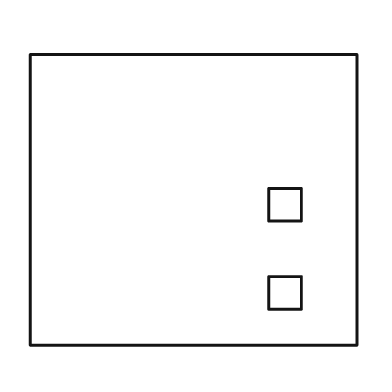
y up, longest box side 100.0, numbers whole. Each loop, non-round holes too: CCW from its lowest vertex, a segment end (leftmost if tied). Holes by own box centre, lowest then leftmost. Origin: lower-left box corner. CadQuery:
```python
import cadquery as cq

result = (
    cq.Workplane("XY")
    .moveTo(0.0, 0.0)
    .lineTo(100.0, 0.0)
    .lineTo(100.0, 89.0)
    .lineTo(0.0, 89.0)
    .close()
    .moveTo(73.0, 11.0)
    .lineTo(83.0, 11.0)
    .lineTo(83.0, 21.0)
    .lineTo(73.0, 21.0)
    .close()
    .moveTo(73.0, 38.0)
    .lineTo(83.0, 38.0)
    .lineTo(83.0, 48.0)
    .lineTo(73.0, 48.0)
    .close()
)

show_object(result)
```